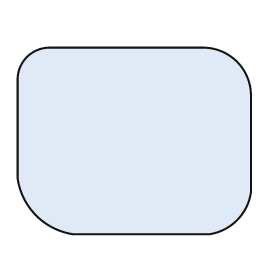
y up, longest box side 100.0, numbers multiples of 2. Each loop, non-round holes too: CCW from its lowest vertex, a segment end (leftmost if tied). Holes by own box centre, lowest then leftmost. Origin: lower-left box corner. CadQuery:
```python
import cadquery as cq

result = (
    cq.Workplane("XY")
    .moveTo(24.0, 0.0)
    .lineTo(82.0, 0.0)
    .threePointArc((94.0, 6.0), (100.0, 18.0))
    .lineTo(100.0, 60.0)
    .threePointArc((94.0, 74.0), (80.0, 80.0))
    .lineTo(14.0, 80.0)
    .threePointArc((4.0, 76.0), (0.0, 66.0))
    .lineTo(0.0, 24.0)
    .threePointArc((8.0, 8.0), (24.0, 0.0))
    .close()
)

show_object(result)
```